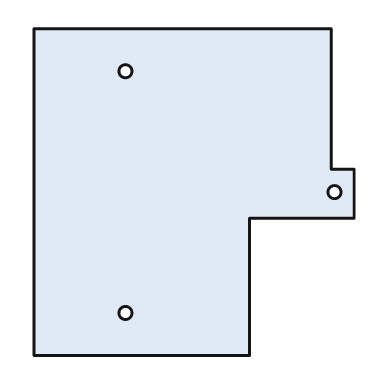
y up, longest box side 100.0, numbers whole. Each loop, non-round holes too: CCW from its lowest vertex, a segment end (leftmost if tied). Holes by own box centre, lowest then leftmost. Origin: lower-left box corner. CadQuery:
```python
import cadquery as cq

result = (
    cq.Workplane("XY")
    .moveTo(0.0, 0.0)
    .lineTo(66.0, 0.0)
    .lineTo(66.0, 42.0)
    .lineTo(98.0, 42.0)
    .lineTo(98.0, 57.0)
    .lineTo(91.0, 57.0)
    .lineTo(91.0, 100.0)
    .lineTo(0.0, 100.0)
    .close()
    .moveTo(28.0, 13.0)
    .circle(2.0)
    .moveTo(92.0, 50.0)
    .circle(2.0)
    .moveTo(28.0, 87.0)
    .circle(2.0)
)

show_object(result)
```